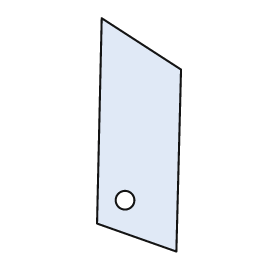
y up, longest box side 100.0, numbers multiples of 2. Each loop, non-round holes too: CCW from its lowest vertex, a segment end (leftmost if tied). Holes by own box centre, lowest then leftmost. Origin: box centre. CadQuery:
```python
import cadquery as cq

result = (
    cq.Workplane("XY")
    .moveTo(16.0, -50.0)
    .lineTo(18.0, 28.0)
    .lineTo(-16.0, 50.0)
    .lineTo(-18.0, -38.0)
    .close()
    .moveTo(-6.0, -28.0)
    .circle(4.0)
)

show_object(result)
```